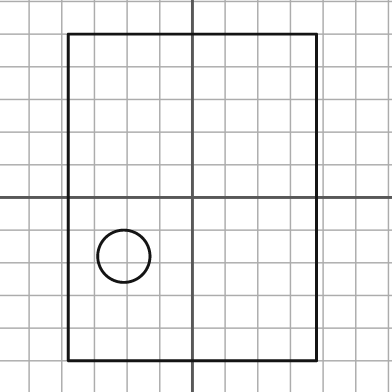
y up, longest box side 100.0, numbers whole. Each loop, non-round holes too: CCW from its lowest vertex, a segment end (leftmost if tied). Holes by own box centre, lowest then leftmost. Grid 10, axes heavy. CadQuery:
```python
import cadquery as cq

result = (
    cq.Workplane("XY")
    .moveTo(-38.0, -50.0)
    .lineTo(38.0, -50.0)
    .lineTo(38.0, 50.0)
    .lineTo(-38.0, 50.0)
    .close()
    .moveTo(-21.0, -18.0)
    .circle(8.0)
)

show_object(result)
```